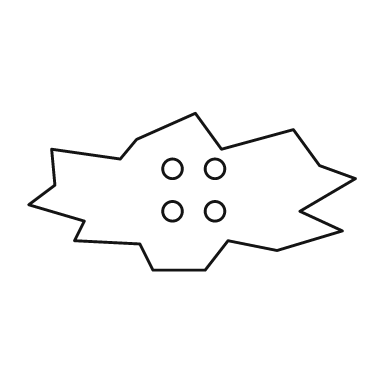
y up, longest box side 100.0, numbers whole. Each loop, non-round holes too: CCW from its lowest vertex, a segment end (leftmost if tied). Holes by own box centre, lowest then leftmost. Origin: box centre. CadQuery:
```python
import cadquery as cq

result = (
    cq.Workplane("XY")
    .moveTo(-12.0, -24.0)
    .lineTo(4.0, -24.0)
    .lineTo(11.0, -15.0)
    .lineTo(26.0, -18.0)
    .lineTo(46.0, -12.0)
    .lineTo(33.0, -6.0)
    .lineTo(50.0, 4.0)
    .lineTo(39.0, 8.0)
    .lineTo(31.0, 19.0)
    .lineTo(9.0, 13.0)
    .lineTo(1.0, 24.0)
    .lineTo(-17.0, 16.0)
    .lineTo(-22.0, 10.0)
    .lineTo(-43.0, 13.0)
    .lineTo(-42.0, 2.0)
    .lineTo(-50.0, -4.0)
    .lineTo(-33.0, -9.0)
    .lineTo(-36.0, -15.0)
    .lineTo(-16.0, -16.0)
    .close()
    .moveTo(-6.0, -6.0)
    .circle(3.0)
    .moveTo(7.0, -6.0)
    .circle(3.0)
    .moveTo(-6.0, 7.0)
    .circle(3.0)
    .moveTo(7.0, 7.0)
    .circle(3.0)
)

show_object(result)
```